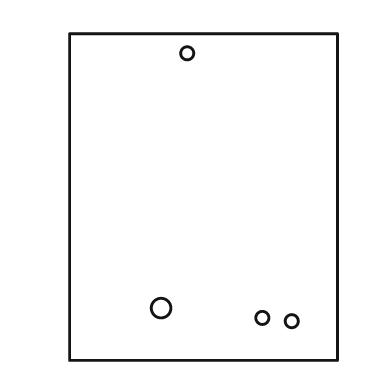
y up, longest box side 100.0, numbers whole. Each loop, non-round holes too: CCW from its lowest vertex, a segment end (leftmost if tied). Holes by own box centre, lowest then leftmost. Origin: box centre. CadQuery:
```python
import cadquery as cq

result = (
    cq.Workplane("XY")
    .moveTo(-41.0, -50.0)
    .lineTo(41.0, -50.0)
    .lineTo(41.0, 50.0)
    .lineTo(-41.0, 50.0)
    .close()
    .moveTo(27.0, -38.0)
    .circle(2.0)
    .moveTo(18.0, -37.0)
    .circle(2.0)
    .moveTo(-13.0, -34.0)
    .circle(3.0)
    .moveTo(-5.0, 44.0)
    .circle(2.0)
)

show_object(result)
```